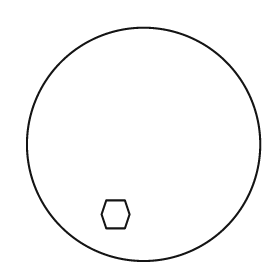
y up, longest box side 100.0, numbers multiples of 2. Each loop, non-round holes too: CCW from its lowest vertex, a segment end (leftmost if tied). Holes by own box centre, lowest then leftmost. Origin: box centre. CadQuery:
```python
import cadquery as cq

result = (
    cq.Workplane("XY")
    .moveTo(0.0, 0.0)
    .circle(50.0)
    .moveTo(-16.0, -36.0)
    .lineTo(-8.0, -36.0)
    .lineTo(-6.0, -30.0)
    .lineTo(-8.0, -24.0)
    .lineTo(-16.0, -24.0)
    .lineTo(-18.0, -30.0)
    .close()
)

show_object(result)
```